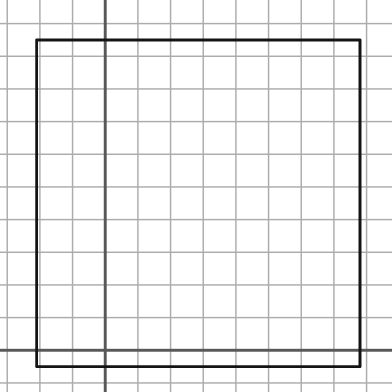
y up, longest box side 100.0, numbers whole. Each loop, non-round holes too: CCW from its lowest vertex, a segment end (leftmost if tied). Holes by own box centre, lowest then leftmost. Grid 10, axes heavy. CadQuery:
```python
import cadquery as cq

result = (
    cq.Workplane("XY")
    .moveTo(-21.0, -5.0)
    .lineTo(78.0, -5.0)
    .lineTo(78.0, 95.0)
    .lineTo(-21.0, 95.0)
    .close()
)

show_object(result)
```